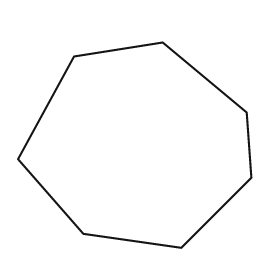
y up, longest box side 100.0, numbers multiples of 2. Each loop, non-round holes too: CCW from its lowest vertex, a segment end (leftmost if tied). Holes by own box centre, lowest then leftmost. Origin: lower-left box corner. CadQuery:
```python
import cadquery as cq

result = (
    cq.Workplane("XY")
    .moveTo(70.0, 0.0)
    .lineTo(100.0, 30.0)
    .lineTo(98.0, 58.0)
    .lineTo(62.0, 88.0)
    .lineTo(24.0, 82.0)
    .lineTo(0.0, 38.0)
    .lineTo(28.0, 6.0)
    .close()
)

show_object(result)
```